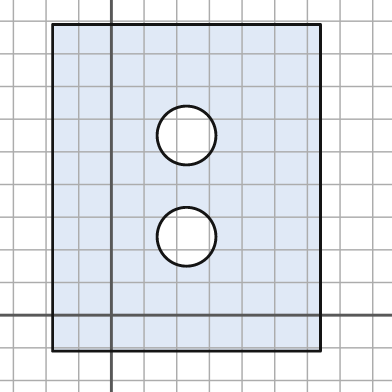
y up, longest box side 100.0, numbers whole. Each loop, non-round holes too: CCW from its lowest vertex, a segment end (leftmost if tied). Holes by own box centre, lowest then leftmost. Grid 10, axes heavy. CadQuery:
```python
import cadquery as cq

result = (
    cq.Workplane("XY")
    .moveTo(-18.0, -11.0)
    .lineTo(64.0, -11.0)
    .lineTo(64.0, 89.0)
    .lineTo(-18.0, 89.0)
    .close()
    .moveTo(23.0, 24.0)
    .circle(9.0)
    .moveTo(23.0, 55.0)
    .circle(9.0)
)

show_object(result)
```